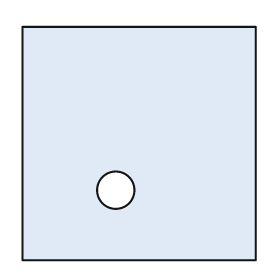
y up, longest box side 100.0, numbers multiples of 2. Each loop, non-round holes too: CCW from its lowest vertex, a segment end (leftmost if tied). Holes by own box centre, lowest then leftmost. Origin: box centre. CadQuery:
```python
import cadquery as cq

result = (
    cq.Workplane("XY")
    .moveTo(-50.0, -50.0)
    .lineTo(50.0, -50.0)
    .lineTo(50.0, 50.0)
    .lineTo(-50.0, 50.0)
    .close()
    .moveTo(-10.0, -20.0)
    .circle(8.0)
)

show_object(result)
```